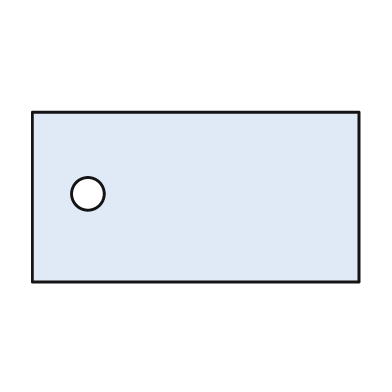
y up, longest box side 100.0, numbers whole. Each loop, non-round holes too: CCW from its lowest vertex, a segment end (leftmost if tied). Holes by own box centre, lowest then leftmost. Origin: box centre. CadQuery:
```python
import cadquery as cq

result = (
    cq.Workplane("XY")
    .moveTo(-50.0, -26.0)
    .lineTo(50.0, -26.0)
    .lineTo(50.0, 26.0)
    .lineTo(-50.0, 26.0)
    .close()
    .moveTo(-33.0, 1.0)
    .circle(5.0)
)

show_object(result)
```